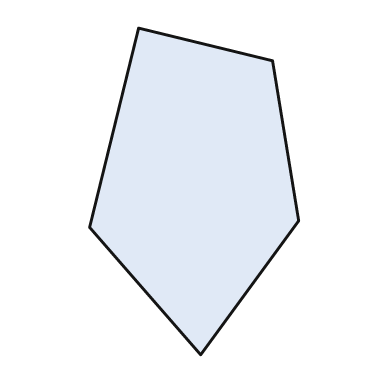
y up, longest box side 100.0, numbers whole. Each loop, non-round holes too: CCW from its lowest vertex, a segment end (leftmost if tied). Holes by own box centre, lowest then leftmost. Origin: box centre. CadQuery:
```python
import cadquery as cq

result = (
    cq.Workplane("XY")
    .moveTo(2.0, -50.0)
    .lineTo(32.0, -9.0)
    .lineTo(24.0, 40.0)
    .lineTo(-17.0, 50.0)
    .lineTo(-32.0, -11.0)
    .close()
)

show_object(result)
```